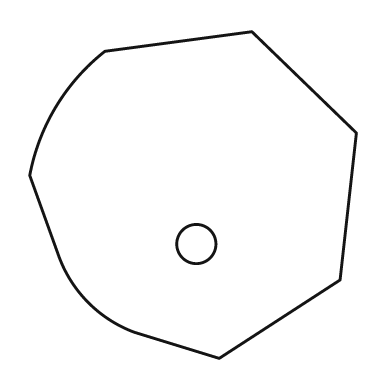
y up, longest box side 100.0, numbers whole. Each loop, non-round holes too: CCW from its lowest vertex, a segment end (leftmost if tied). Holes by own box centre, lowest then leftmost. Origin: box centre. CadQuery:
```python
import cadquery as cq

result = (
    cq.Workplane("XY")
    .moveTo(8.0, -50.0)
    .lineTo(45.0, -26.0)
    .lineTo(50.0, 19.0)
    .lineTo(18.0, 50.0)
    .lineTo(-27.0, 44.0)
    .threePointArc((-42.0, 27.0), (-50.0, 6.0))
    .lineTo(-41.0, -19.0)
    .threePointArc((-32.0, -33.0), (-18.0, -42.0))
    .close()
    .moveTo(1.0, -15.0)
    .circle(6.0)
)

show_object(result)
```